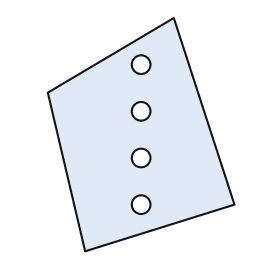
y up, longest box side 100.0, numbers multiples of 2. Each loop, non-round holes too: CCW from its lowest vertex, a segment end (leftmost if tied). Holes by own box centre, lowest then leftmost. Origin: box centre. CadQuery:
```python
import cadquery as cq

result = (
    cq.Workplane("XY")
    .moveTo(-24.0, -50.0)
    .lineTo(40.0, -30.0)
    .lineTo(14.0, 50.0)
    .lineTo(-40.0, 18.0)
    .close()
    .moveTo(0.0, -30.0)
    .circle(4.0)
    .moveTo(0.0, -10.0)
    .circle(4.0)
    .moveTo(0.0, 10.0)
    .circle(4.0)
    .moveTo(0.0, 30.0)
    .circle(4.0)
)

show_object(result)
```